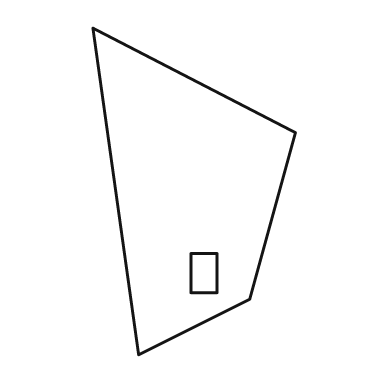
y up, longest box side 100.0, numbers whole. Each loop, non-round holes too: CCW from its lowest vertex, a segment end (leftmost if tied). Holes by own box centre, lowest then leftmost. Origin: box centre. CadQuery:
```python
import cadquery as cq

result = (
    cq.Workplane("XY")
    .moveTo(-17.0, -50.0)
    .lineTo(17.0, -33.0)
    .lineTo(31.0, 18.0)
    .lineTo(-31.0, 50.0)
    .close()
    .moveTo(-1.0, -31.0)
    .lineTo(7.0, -31.0)
    .lineTo(7.0, -19.0)
    .lineTo(-1.0, -19.0)
    .close()
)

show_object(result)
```